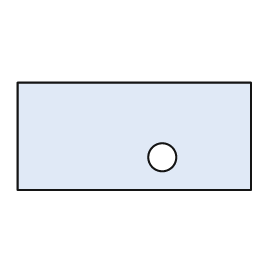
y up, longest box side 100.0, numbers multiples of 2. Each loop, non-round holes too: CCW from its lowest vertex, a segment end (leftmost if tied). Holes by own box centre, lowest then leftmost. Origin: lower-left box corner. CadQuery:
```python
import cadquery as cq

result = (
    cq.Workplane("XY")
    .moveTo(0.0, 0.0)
    .lineTo(100.0, 0.0)
    .lineTo(100.0, 46.0)
    .lineTo(0.0, 46.0)
    .close()
    .moveTo(62.0, 14.0)
    .circle(6.0)
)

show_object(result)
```